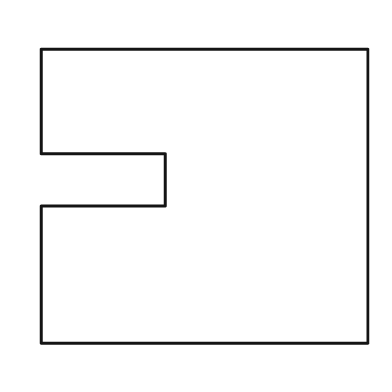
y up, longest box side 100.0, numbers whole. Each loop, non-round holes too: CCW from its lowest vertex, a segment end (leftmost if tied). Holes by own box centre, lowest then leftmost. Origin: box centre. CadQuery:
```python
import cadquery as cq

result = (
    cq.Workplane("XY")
    .moveTo(-50.0, -45.0)
    .lineTo(50.0, -45.0)
    .lineTo(50.0, 45.0)
    .lineTo(-50.0, 45.0)
    .lineTo(-50.0, 13.0)
    .lineTo(-12.0, 13.0)
    .lineTo(-12.0, -3.0)
    .lineTo(-50.0, -3.0)
    .close()
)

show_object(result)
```